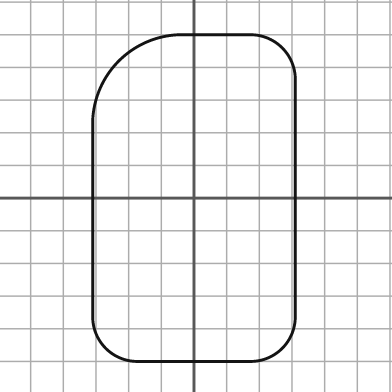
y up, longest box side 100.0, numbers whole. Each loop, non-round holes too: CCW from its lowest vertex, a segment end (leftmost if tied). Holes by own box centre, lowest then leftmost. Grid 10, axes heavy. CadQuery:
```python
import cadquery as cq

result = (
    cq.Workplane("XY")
    .moveTo(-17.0, -50.0)
    .lineTo(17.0, -50.0)
    .threePointArc((27.0, -46.0), (31.0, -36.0))
    .lineTo(31.0, 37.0)
    .threePointArc((27.0, 46.0), (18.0, 50.0))
    .lineTo(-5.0, 50.0)
    .threePointArc((-23.0, 42.0), (-31.0, 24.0))
    .lineTo(-31.0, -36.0)
    .threePointArc((-27.0, -46.0), (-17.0, -50.0))
    .close()
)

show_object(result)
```